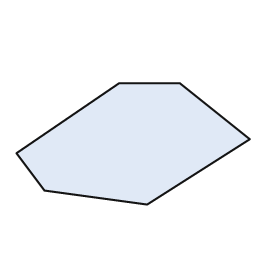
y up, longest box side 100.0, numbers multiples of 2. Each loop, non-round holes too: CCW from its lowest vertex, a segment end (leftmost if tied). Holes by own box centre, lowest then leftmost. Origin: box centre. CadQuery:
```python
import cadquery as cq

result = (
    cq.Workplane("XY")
    .moveTo(6.0, -26.0)
    .lineTo(50.0, 2.0)
    .lineTo(20.0, 26.0)
    .lineTo(-6.0, 26.0)
    .lineTo(-50.0, -4.0)
    .lineTo(-38.0, -20.0)
    .close()
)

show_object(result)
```